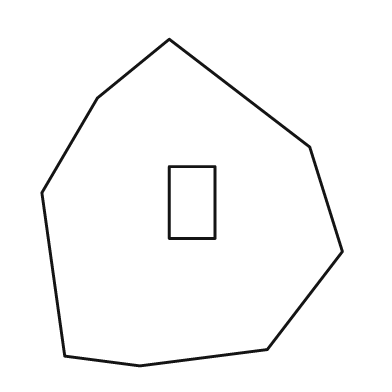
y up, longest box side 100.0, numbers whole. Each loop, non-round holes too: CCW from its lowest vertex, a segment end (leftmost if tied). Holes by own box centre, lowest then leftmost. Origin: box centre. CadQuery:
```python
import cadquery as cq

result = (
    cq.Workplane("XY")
    .moveTo(-16.0, -50.0)
    .lineTo(23.0, -45.0)
    .lineTo(46.0, -15.0)
    .lineTo(36.0, 17.0)
    .lineTo(-7.0, 50.0)
    .lineTo(-29.0, 32.0)
    .lineTo(-46.0, 3.0)
    .lineTo(-39.0, -47.0)
    .close()
    .moveTo(-7.0, -11.0)
    .lineTo(7.0, -11.0)
    .lineTo(7.0, 11.0)
    .lineTo(-7.0, 11.0)
    .close()
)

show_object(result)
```